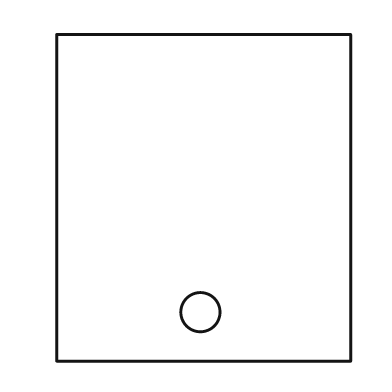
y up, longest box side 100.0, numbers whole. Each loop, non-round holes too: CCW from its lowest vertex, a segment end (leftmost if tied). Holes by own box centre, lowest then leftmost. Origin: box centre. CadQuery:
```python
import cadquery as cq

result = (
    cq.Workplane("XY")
    .moveTo(-45.0, -50.0)
    .lineTo(45.0, -50.0)
    .lineTo(45.0, 50.0)
    .lineTo(-45.0, 50.0)
    .close()
    .moveTo(-1.0, -35.0)
    .circle(6.0)
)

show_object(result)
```